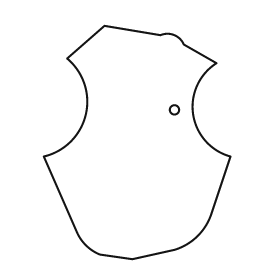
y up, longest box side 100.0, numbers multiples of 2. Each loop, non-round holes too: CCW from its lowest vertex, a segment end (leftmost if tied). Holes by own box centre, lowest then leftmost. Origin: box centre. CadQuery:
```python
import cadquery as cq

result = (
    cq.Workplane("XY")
    .moveTo(-2.0, -50.0)
    .lineTo(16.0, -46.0)
    .threePointArc((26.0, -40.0), (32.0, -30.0))
    .lineTo(40.0, -6.0)
    .threePointArc((24.0, 12.0), (34.0, 34.0))
    .lineTo(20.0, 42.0)
    .threePointArc((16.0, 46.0), (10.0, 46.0))
    .lineTo(-14.0, 50.0)
    .lineTo(-30.0, 36.0)
    .threePointArc((-22.0, 12.0), (-40.0, -6.0))
    .lineTo(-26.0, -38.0)
    .threePointArc((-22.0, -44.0), (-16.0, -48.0))
    .close()
    .moveTo(16.0, 14.0)
    .circle(2.0)
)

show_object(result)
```